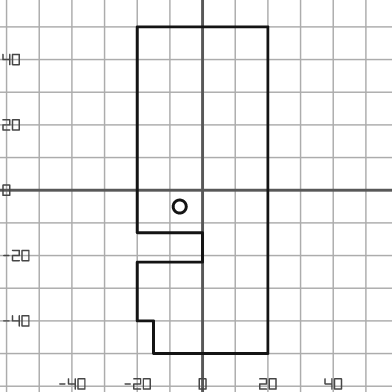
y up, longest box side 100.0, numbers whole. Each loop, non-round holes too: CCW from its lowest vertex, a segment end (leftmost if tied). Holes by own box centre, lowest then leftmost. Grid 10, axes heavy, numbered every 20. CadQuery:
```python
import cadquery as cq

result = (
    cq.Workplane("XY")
    .moveTo(-15.0, -50.0)
    .lineTo(20.0, -50.0)
    .lineTo(20.0, 50.0)
    .lineTo(-20.0, 50.0)
    .lineTo(-20.0, -13.0)
    .lineTo(0.0, -13.0)
    .lineTo(0.0, -22.0)
    .lineTo(-20.0, -22.0)
    .lineTo(-20.0, -40.0)
    .lineTo(-15.0, -40.0)
    .close()
    .moveTo(-7.0, -5.0)
    .circle(2.0)
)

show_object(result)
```